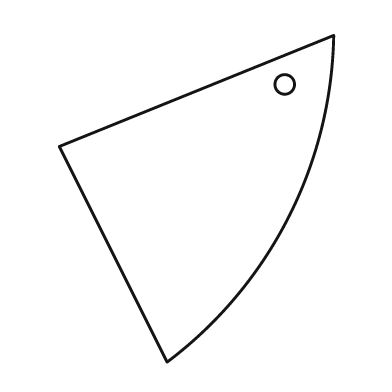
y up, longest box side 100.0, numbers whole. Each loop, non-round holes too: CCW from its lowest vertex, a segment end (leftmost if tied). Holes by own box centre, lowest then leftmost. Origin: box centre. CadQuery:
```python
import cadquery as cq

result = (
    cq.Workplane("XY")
    .moveTo(-9.0, -50.0)
    .threePointArc((28.0, -6.0), (42.0, 50.0))
    .lineTo(-42.0, 16.0)
    .close()
    .moveTo(27.0, 35.0)
    .circle(3.0)
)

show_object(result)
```